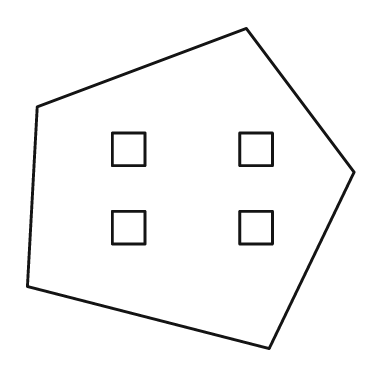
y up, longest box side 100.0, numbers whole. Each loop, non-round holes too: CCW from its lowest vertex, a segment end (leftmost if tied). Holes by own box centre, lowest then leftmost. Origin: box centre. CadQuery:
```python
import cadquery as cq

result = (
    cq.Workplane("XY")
    .moveTo(24.0, -49.0)
    .lineTo(50.0, 5.0)
    .lineTo(17.0, 49.0)
    .lineTo(-47.0, 25.0)
    .lineTo(-50.0, -30.0)
    .close()
    .moveTo(-24.0, -17.0)
    .lineTo(-14.0, -17.0)
    .lineTo(-14.0, -7.0)
    .lineTo(-24.0, -7.0)
    .close()
    .moveTo(15.0, -17.0)
    .lineTo(25.0, -17.0)
    .lineTo(25.0, -7.0)
    .lineTo(15.0, -7.0)
    .close()
    .moveTo(-24.0, 7.0)
    .lineTo(-14.0, 7.0)
    .lineTo(-14.0, 17.0)
    .lineTo(-24.0, 17.0)
    .close()
    .moveTo(15.0, 7.0)
    .lineTo(25.0, 7.0)
    .lineTo(25.0, 17.0)
    .lineTo(15.0, 17.0)
    .close()
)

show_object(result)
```